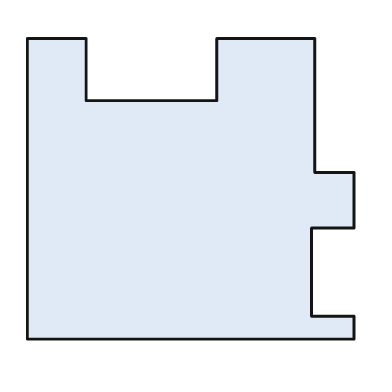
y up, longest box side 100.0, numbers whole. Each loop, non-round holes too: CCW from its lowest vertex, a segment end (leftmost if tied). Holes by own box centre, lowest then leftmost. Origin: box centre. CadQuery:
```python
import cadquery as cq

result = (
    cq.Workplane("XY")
    .moveTo(-50.0, -46.0)
    .lineTo(50.0, -46.0)
    .lineTo(50.0, -39.0)
    .lineTo(37.0, -39.0)
    .lineTo(37.0, -12.0)
    .lineTo(50.0, -12.0)
    .lineTo(50.0, 5.0)
    .lineTo(38.0, 5.0)
    .lineTo(38.0, 46.0)
    .lineTo(8.0, 46.0)
    .lineTo(8.0, 27.0)
    .lineTo(-32.0, 27.0)
    .lineTo(-32.0, 46.0)
    .lineTo(-50.0, 46.0)
    .close()
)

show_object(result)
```